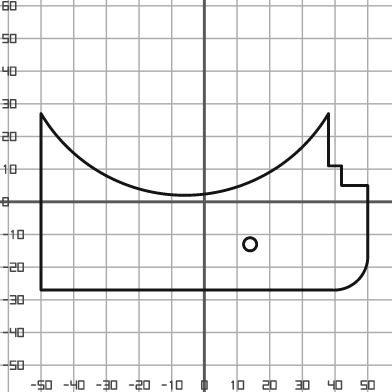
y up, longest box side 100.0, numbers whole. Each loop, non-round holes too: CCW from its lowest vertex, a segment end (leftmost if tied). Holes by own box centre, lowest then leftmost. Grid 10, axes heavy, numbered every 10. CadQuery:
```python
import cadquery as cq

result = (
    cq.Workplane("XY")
    .moveTo(-50.0, -27.0)
    .lineTo(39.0, -27.0)
    .threePointArc((47.0, -24.0), (50.0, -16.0))
    .lineTo(50.0, 5.0)
    .lineTo(42.0, 5.0)
    .lineTo(42.0, 11.0)
    .lineTo(38.0, 11.0)
    .lineTo(38.0, 27.0)
    .threePointArc((-6.0, 2.0), (-50.0, 27.0))
    .close()
    .moveTo(14.0, -13.0)
    .circle(2.0)
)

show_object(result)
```